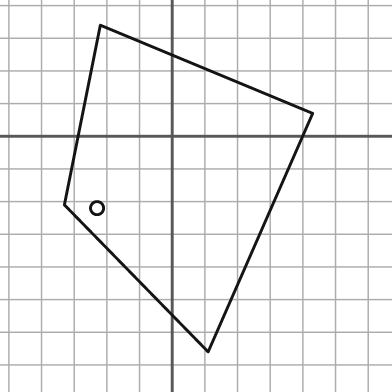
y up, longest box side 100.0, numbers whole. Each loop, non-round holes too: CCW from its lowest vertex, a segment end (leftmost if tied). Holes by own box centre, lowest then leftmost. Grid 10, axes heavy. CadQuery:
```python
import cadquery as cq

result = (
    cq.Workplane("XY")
    .moveTo(11.0, -66.0)
    .lineTo(43.0, 7.0)
    .lineTo(-22.0, 34.0)
    .lineTo(-33.0, -21.0)
    .close()
    .moveTo(-23.0, -22.0)
    .circle(2.0)
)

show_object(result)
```